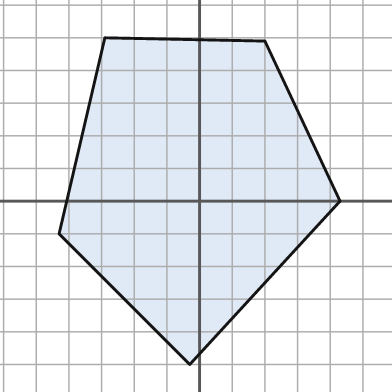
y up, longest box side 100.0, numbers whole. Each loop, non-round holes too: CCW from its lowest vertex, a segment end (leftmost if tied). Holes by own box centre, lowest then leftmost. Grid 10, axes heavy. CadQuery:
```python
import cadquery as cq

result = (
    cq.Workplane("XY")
    .moveTo(-3.0, -50.0)
    .lineTo(43.0, 0.0)
    .lineTo(20.0, 49.0)
    .lineTo(-29.0, 50.0)
    .lineTo(-43.0, -10.0)
    .close()
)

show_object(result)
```